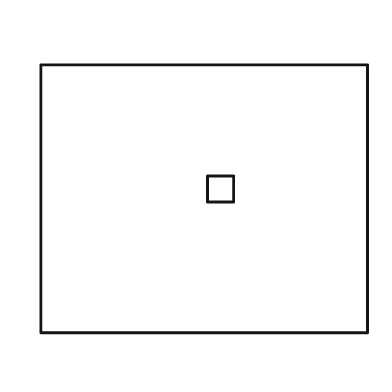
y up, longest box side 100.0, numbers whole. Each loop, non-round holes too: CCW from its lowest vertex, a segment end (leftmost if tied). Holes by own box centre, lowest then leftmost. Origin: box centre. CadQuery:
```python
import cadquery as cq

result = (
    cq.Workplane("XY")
    .moveTo(-50.0, -41.0)
    .lineTo(50.0, -41.0)
    .lineTo(50.0, 41.0)
    .lineTo(-50.0, 41.0)
    .close()
    .moveTo(1.0, -1.0)
    .lineTo(9.0, -1.0)
    .lineTo(9.0, 7.0)
    .lineTo(1.0, 7.0)
    .close()
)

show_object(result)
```